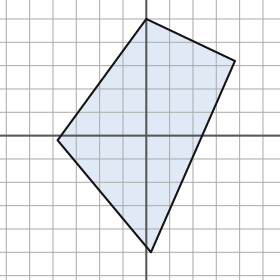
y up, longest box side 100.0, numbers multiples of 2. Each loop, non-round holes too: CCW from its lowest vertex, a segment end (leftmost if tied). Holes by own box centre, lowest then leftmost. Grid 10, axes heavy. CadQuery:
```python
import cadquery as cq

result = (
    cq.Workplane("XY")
    .moveTo(2.0, -50.0)
    .lineTo(38.0, 32.0)
    .lineTo(0.0, 50.0)
    .lineTo(-38.0, -2.0)
    .close()
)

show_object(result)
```